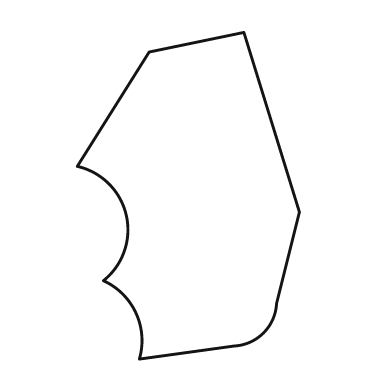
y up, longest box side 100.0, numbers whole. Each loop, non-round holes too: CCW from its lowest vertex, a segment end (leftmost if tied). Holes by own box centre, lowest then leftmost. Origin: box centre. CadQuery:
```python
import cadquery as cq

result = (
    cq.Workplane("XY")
    .moveTo(-15.0, -50.0)
    .lineTo(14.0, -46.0)
    .threePointArc((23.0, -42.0), (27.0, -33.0))
    .lineTo(34.0, -5.0)
    .lineTo(17.0, 50.0)
    .lineTo(-12.0, 44.0)
    .lineTo(-34.0, 9.0)
    .threePointArc((-19.0, -6.0), (-26.0, -26.0))
    .threePointArc((-16.0, -36.0), (-15.0, -50.0))
    .close()
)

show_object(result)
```